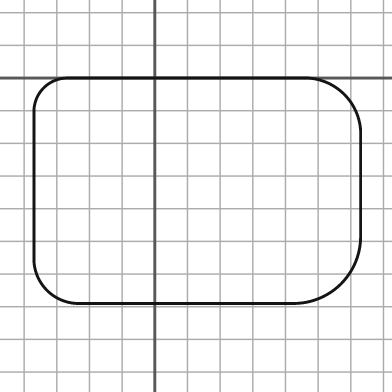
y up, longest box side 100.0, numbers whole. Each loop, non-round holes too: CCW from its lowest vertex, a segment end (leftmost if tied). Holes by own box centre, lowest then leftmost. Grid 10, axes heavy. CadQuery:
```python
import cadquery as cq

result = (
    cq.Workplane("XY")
    .moveTo(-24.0, -69.0)
    .lineTo(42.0, -69.0)
    .threePointArc((57.0, -63.0), (63.0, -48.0))
    .lineTo(63.0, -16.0)
    .threePointArc((58.0, -5.0), (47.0, 0.0))
    .lineTo(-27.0, 0.0)
    .threePointArc((-34.0, -3.0), (-37.0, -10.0))
    .lineTo(-37.0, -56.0)
    .threePointArc((-33.0, -65.0), (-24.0, -69.0))
    .close()
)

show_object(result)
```